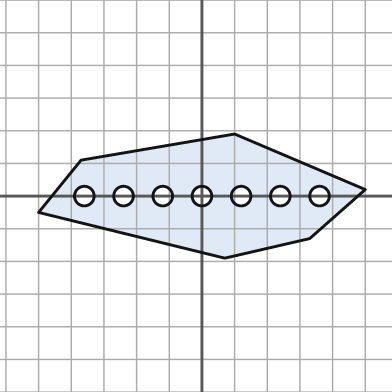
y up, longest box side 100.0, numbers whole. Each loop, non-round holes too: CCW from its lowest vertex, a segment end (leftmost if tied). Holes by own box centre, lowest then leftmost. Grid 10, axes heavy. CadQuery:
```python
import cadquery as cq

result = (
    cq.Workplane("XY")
    .moveTo(7.0, -19.0)
    .lineTo(33.0, -13.0)
    .lineTo(50.0, 2.0)
    .lineTo(10.0, 19.0)
    .lineTo(-37.0, 11.0)
    .lineTo(-50.0, -5.0)
    .close()
    .moveTo(-36.0, 0.0)
    .circle(3.0)
    .moveTo(-24.0, 0.0)
    .circle(3.0)
    .moveTo(-12.0, 0.0)
    .circle(3.0)
    .moveTo(0.0, 0.0)
    .circle(3.0)
    .moveTo(12.0, 0.0)
    .circle(3.0)
    .moveTo(24.0, 0.0)
    .circle(3.0)
    .moveTo(36.0, 0.0)
    .circle(3.0)
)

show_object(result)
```